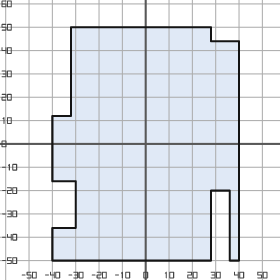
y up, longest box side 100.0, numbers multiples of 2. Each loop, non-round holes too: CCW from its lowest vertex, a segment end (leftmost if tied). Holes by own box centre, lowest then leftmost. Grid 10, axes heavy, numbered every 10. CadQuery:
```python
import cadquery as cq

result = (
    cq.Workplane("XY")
    .moveTo(-40.0, -50.0)
    .lineTo(28.0, -50.0)
    .lineTo(28.0, -20.0)
    .lineTo(36.0, -20.0)
    .lineTo(36.0, -50.0)
    .lineTo(40.0, -50.0)
    .lineTo(40.0, 44.0)
    .lineTo(28.0, 44.0)
    .lineTo(28.0, 50.0)
    .lineTo(-32.0, 50.0)
    .lineTo(-32.0, 12.0)
    .lineTo(-40.0, 12.0)
    .lineTo(-40.0, -16.0)
    .lineTo(-30.0, -16.0)
    .lineTo(-30.0, -36.0)
    .lineTo(-40.0, -36.0)
    .close()
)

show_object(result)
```